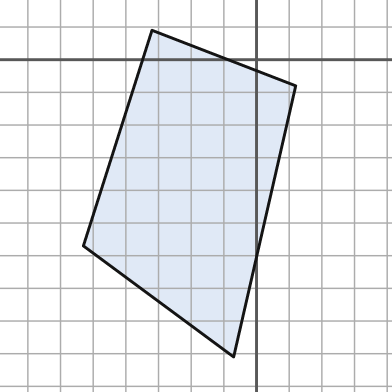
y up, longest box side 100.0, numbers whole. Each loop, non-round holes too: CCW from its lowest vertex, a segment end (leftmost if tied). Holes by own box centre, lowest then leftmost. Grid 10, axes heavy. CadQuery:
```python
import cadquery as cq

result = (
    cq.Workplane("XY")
    .moveTo(-7.0, -91.0)
    .lineTo(12.0, -8.0)
    .lineTo(-32.0, 9.0)
    .lineTo(-53.0, -57.0)
    .close()
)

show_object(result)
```